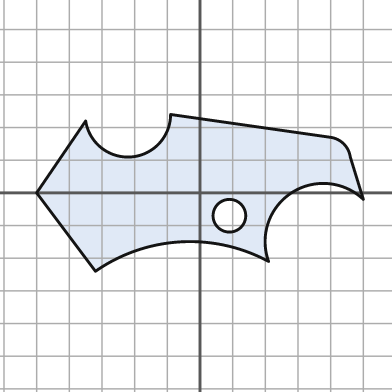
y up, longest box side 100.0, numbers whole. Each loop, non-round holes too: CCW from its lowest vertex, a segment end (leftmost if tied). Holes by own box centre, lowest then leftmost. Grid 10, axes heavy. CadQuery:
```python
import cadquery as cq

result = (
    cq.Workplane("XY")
    .moveTo(-32.0, -24.0)
    .threePointArc((-6.0, -15.0), (21.0, -21.0))
    .threePointArc((28.0, 0.0), (50.0, -2.0))
    .lineTo(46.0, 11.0)
    .threePointArc((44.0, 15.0), (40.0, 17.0))
    .lineTo(-9.0, 24.0)
    .threePointArc((-21.0, 11.0), (-35.0, 22.0))
    .lineTo(-50.0, 0.0)
    .close()
    .moveTo(9.0, -7.0)
    .circle(5.0)
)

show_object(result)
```